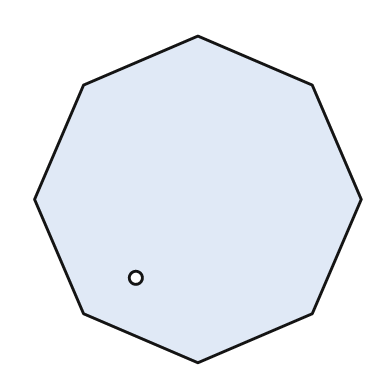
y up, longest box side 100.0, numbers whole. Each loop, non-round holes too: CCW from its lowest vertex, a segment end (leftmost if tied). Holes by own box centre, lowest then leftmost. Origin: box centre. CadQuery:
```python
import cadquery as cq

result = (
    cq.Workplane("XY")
    .moveTo(0.0, -50.0)
    .lineTo(35.0, -35.0)
    .lineTo(50.0, 0.0)
    .lineTo(35.0, 35.0)
    .lineTo(0.0, 50.0)
    .lineTo(-35.0, 35.0)
    .lineTo(-50.0, 0.0)
    .lineTo(-35.0, -35.0)
    .close()
    .moveTo(-19.0, -24.0)
    .circle(2.0)
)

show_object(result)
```